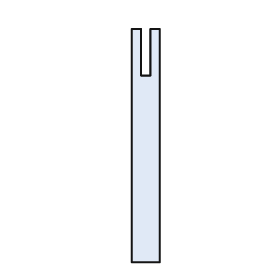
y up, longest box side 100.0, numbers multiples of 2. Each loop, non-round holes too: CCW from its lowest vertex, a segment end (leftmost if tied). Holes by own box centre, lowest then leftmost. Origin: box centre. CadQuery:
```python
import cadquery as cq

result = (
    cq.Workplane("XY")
    .moveTo(-6.0, -50.0)
    .lineTo(6.0, -50.0)
    .lineTo(6.0, 50.0)
    .lineTo(2.0, 50.0)
    .lineTo(2.0, 30.0)
    .lineTo(-2.0, 30.0)
    .lineTo(-2.0, 50.0)
    .lineTo(-6.0, 50.0)
    .close()
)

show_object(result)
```